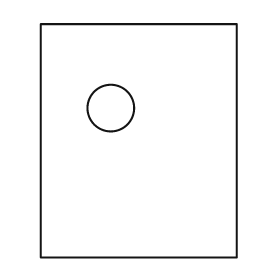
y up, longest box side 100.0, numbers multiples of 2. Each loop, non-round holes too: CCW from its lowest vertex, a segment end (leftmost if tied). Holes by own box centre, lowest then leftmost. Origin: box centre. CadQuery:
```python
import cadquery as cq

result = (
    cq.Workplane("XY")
    .moveTo(-42.0, -50.0)
    .lineTo(42.0, -50.0)
    .lineTo(42.0, 50.0)
    .lineTo(-42.0, 50.0)
    .close()
    .moveTo(-12.0, 14.0)
    .circle(10.0)
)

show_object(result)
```